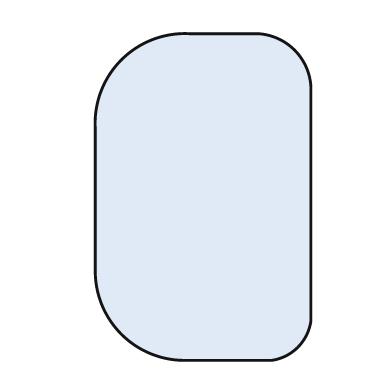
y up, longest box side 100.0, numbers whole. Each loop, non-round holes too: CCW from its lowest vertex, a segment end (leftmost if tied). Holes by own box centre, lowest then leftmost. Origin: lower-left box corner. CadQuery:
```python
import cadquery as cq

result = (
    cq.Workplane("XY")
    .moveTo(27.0, 0.0)
    .lineTo(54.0, 0.0)
    .threePointArc((62.0, 4.0), (66.0, 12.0))
    .lineTo(66.0, 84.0)
    .threePointArc((61.0, 95.0), (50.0, 100.0))
    .lineTo(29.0, 100.0)
    .threePointArc((8.0, 92.0), (0.0, 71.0))
    .lineTo(0.0, 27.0)
    .threePointArc((8.0, 8.0), (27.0, 0.0))
    .close()
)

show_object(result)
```